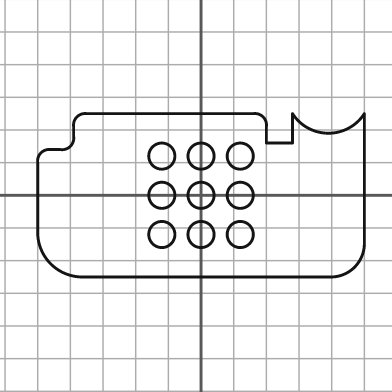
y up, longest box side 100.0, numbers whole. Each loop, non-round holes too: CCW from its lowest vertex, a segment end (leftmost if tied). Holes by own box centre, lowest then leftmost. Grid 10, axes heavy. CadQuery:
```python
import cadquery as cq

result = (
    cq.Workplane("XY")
    .moveTo(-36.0, -25.0)
    .lineTo(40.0, -25.0)
    .threePointArc((47.0, -22.0), (50.0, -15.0))
    .lineTo(50.0, 25.0)
    .threePointArc((39.0, 19.0), (28.0, 25.0))
    .lineTo(28.0, 16.0)
    .lineTo(20.0, 16.0)
    .lineTo(20.0, 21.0)
    .threePointArc((19.0, 24.0), (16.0, 25.0))
    .lineTo(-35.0, 25.0)
    .threePointArc((-38.0, 24.0), (-39.0, 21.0))
    .lineTo(-39.0, 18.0)
    .threePointArc((-40.0, 15.0), (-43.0, 14.0))
    .lineTo(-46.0, 14.0)
    .threePointArc((-49.0, 13.0), (-50.0, 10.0))
    .lineTo(-50.0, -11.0)
    .threePointArc((-46.0, -21.0), (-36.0, -25.0))
    .close()
    .moveTo(-12.0, -12.0)
    .circle(4.0)
    .moveTo(0.0, -12.0)
    .circle(4.0)
    .moveTo(12.0, -12.0)
    .circle(4.0)
    .moveTo(-12.0, 0.0)
    .circle(4.0)
    .moveTo(0.0, 0.0)
    .circle(4.0)
    .moveTo(12.0, 0.0)
    .circle(4.0)
    .moveTo(-12.0, 12.0)
    .circle(4.0)
    .moveTo(0.0, 12.0)
    .circle(4.0)
    .moveTo(12.0, 12.0)
    .circle(4.0)
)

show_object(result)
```